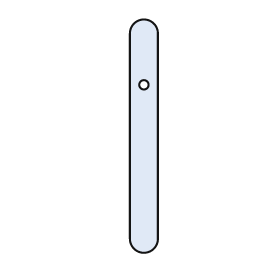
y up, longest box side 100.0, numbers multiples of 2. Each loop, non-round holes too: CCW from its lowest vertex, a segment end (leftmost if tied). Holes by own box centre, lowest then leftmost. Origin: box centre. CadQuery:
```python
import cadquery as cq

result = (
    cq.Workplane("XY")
    .moveTo(-6.0, -44.0)
    .threePointArc((0.0, -50.0), (6.0, -44.0))
    .lineTo(6.0, 44.0)
    .threePointArc((0.0, 50.0), (-6.0, 44.0))
    .close()
    .moveTo(0.0, 22.0)
    .circle(2.0)
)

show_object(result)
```